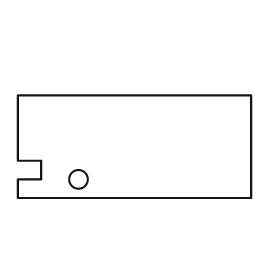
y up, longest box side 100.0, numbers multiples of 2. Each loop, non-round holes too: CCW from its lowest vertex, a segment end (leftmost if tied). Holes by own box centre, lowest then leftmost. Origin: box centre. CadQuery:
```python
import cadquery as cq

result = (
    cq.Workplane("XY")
    .moveTo(-50.0, -22.0)
    .lineTo(50.0, -22.0)
    .lineTo(50.0, 22.0)
    .lineTo(-50.0, 22.0)
    .lineTo(-50.0, -6.0)
    .lineTo(-40.0, -6.0)
    .lineTo(-40.0, -14.0)
    .lineTo(-50.0, -14.0)
    .close()
    .moveTo(-24.0, -14.0)
    .circle(4.0)
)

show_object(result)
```